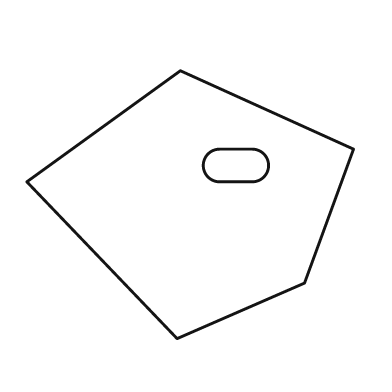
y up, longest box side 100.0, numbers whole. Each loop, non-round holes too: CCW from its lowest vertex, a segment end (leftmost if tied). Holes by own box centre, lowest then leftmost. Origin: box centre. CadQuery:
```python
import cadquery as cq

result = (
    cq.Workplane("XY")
    .moveTo(-4.0, -41.0)
    .lineTo(35.0, -24.0)
    .lineTo(50.0, 17.0)
    .lineTo(-3.0, 41.0)
    .lineTo(-50.0, 7.0)
    .close()
    .moveTo(9.0, 7.0)
    .lineTo(19.0, 7.0)
    .threePointArc((24.0, 12.0), (19.0, 17.0))
    .lineTo(9.0, 17.0)
    .threePointArc((4.0, 12.0), (9.0, 7.0))
    .close()
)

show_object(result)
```